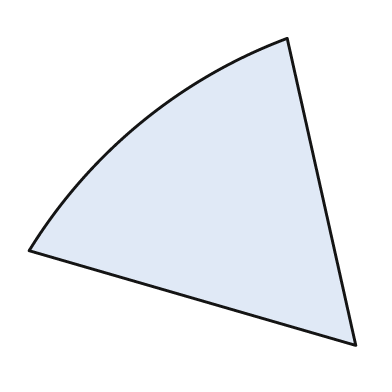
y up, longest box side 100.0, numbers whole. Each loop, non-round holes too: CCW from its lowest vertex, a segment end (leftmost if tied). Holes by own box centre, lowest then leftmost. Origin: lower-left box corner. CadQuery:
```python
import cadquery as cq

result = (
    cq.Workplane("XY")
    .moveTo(100.0, 0.0)
    .lineTo(79.0, 94.0)
    .threePointArc((34.0, 68.0), (0.0, 29.0))
    .close()
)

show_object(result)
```